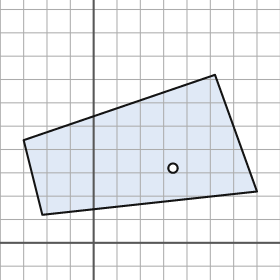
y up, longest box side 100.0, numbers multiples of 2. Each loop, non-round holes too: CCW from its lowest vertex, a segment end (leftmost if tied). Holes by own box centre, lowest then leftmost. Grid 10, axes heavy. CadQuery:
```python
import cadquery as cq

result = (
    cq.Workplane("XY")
    .moveTo(-22.0, 12.0)
    .lineTo(70.0, 22.0)
    .lineTo(52.0, 72.0)
    .lineTo(-30.0, 44.0)
    .close()
    .moveTo(34.0, 32.0)
    .circle(2.0)
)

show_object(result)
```